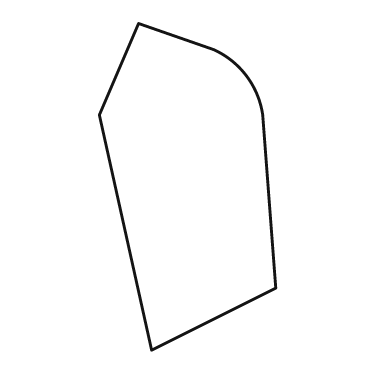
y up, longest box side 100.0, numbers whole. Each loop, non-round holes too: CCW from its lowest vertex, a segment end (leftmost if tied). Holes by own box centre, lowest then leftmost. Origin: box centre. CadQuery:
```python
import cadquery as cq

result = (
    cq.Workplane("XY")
    .moveTo(-11.0, -50.0)
    .lineTo(27.0, -31.0)
    .lineTo(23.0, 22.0)
    .threePointArc((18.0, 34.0), (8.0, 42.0))
    .lineTo(-15.0, 50.0)
    .lineTo(-27.0, 22.0)
    .close()
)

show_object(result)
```